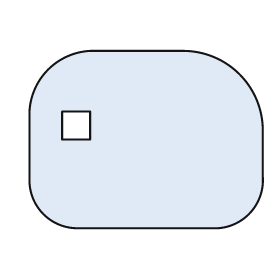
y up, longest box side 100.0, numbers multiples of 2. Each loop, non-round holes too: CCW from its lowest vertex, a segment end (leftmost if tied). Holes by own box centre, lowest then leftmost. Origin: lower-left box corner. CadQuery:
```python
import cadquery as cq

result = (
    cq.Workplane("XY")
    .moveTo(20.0, 0.0)
    .lineTo(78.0, 0.0)
    .threePointArc((94.0, 6.0), (100.0, 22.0))
    .lineTo(100.0, 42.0)
    .threePointArc((90.0, 66.0), (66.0, 76.0))
    .lineTo(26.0, 76.0)
    .threePointArc((8.0, 68.0), (0.0, 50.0))
    .lineTo(0.0, 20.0)
    .threePointArc((6.0, 6.0), (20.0, 0.0))
    .close()
    .moveTo(14.0, 38.0)
    .lineTo(26.0, 38.0)
    .lineTo(26.0, 50.0)
    .lineTo(14.0, 50.0)
    .close()
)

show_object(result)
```